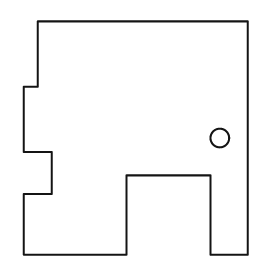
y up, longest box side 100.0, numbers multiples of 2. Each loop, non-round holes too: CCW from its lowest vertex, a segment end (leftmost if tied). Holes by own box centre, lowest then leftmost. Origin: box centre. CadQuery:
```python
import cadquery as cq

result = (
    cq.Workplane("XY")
    .moveTo(-48.0, -50.0)
    .lineTo(-4.0, -50.0)
    .lineTo(-4.0, -16.0)
    .lineTo(32.0, -16.0)
    .lineTo(32.0, -50.0)
    .lineTo(48.0, -50.0)
    .lineTo(48.0, 50.0)
    .lineTo(-42.0, 50.0)
    .lineTo(-42.0, 22.0)
    .lineTo(-48.0, 22.0)
    .lineTo(-48.0, -6.0)
    .lineTo(-36.0, -6.0)
    .lineTo(-36.0, -24.0)
    .lineTo(-48.0, -24.0)
    .close()
    .moveTo(36.0, 0.0)
    .circle(4.0)
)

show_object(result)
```